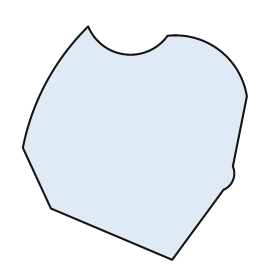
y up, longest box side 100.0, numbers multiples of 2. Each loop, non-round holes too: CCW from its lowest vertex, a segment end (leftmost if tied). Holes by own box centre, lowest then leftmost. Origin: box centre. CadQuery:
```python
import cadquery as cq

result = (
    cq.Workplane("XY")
    .moveTo(16.0, -50.0)
    .lineTo(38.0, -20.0)
    .threePointArc((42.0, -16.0), (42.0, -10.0))
    .lineTo(48.0, 20.0)
    .threePointArc((36.0, 40.0), (14.0, 46.0))
    .threePointArc((-4.0, 38.0), (-20.0, 50.0))
    .threePointArc((-38.0, 26.0), (-48.0, -2.0))
    .lineTo(-36.0, -28.0)
    .close()
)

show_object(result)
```